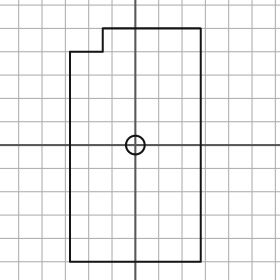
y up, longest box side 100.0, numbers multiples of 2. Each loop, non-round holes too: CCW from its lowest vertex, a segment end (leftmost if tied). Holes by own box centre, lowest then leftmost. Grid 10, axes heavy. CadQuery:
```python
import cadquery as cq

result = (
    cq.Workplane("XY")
    .moveTo(-28.0, -50.0)
    .lineTo(28.0, -50.0)
    .lineTo(28.0, 50.0)
    .lineTo(-14.0, 50.0)
    .lineTo(-14.0, 40.0)
    .lineTo(-28.0, 40.0)
    .close()
    .moveTo(0.0, 0.0)
    .circle(4.0)
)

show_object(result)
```